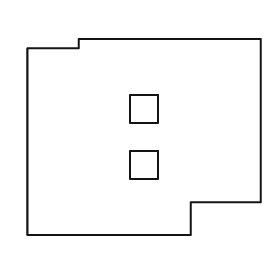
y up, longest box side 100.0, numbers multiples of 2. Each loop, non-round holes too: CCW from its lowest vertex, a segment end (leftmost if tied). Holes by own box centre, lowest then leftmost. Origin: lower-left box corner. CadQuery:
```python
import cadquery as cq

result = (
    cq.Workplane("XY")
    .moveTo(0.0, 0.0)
    .lineTo(70.0, 0.0)
    .lineTo(70.0, 14.0)
    .lineTo(100.0, 14.0)
    .lineTo(100.0, 84.0)
    .lineTo(22.0, 84.0)
    .lineTo(22.0, 80.0)
    .lineTo(0.0, 80.0)
    .close()
    .moveTo(44.0, 24.0)
    .lineTo(56.0, 24.0)
    .lineTo(56.0, 36.0)
    .lineTo(44.0, 36.0)
    .close()
    .moveTo(44.0, 48.0)
    .lineTo(56.0, 48.0)
    .lineTo(56.0, 60.0)
    .lineTo(44.0, 60.0)
    .close()
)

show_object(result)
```